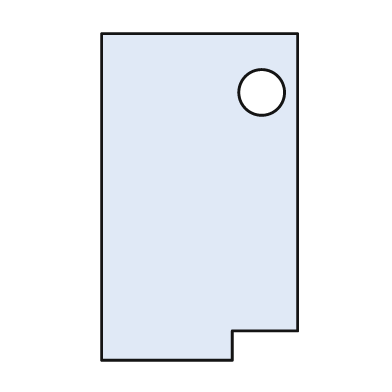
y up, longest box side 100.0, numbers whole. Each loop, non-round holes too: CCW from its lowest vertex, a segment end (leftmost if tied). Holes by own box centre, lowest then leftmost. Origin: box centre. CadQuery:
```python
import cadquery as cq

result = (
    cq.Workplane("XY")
    .moveTo(-30.0, -50.0)
    .lineTo(10.0, -50.0)
    .lineTo(10.0, -41.0)
    .lineTo(30.0, -41.0)
    .lineTo(30.0, 50.0)
    .lineTo(-30.0, 50.0)
    .close()
    .moveTo(19.0, 32.0)
    .circle(7.0)
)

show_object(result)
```